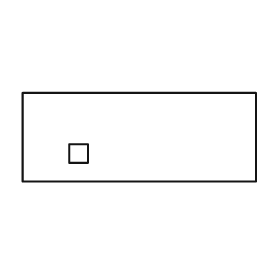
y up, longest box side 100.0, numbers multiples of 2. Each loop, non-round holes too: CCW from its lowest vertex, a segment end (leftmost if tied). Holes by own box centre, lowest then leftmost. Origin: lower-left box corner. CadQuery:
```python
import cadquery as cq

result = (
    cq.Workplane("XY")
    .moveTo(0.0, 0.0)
    .lineTo(100.0, 0.0)
    .lineTo(100.0, 38.0)
    .lineTo(0.0, 38.0)
    .close()
    .moveTo(20.0, 8.0)
    .lineTo(28.0, 8.0)
    .lineTo(28.0, 16.0)
    .lineTo(20.0, 16.0)
    .close()
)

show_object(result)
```